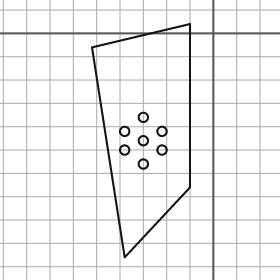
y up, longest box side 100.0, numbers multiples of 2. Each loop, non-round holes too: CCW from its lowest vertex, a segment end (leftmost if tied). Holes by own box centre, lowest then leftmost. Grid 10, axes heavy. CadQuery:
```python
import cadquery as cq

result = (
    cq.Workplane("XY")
    .moveTo(-38.0, -96.0)
    .lineTo(-10.0, -66.0)
    .lineTo(-10.0, 4.0)
    .lineTo(-52.0, -6.0)
    .close()
    .moveTo(-30.0, -56.0)
    .circle(2.0)
    .moveTo(-38.0, -50.0)
    .circle(2.0)
    .moveTo(-22.0, -50.0)
    .circle(2.0)
    .moveTo(-30.0, -46.0)
    .circle(2.0)
    .moveTo(-38.0, -42.0)
    .circle(2.0)
    .moveTo(-22.0, -42.0)
    .circle(2.0)
    .moveTo(-30.0, -36.0)
    .circle(2.0)
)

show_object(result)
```